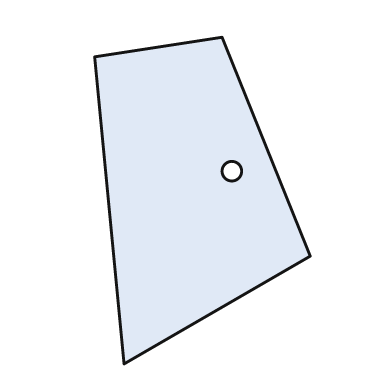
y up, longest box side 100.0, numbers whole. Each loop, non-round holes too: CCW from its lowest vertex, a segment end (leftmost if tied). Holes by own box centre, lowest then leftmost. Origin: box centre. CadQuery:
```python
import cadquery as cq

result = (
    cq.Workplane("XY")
    .moveTo(-24.0, -50.0)
    .lineTo(33.0, -17.0)
    .lineTo(6.0, 50.0)
    .lineTo(-33.0, 44.0)
    .close()
    .moveTo(9.0, 9.0)
    .circle(3.0)
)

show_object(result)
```